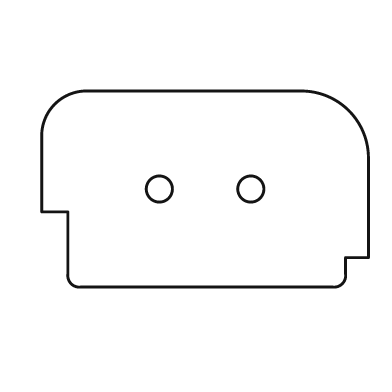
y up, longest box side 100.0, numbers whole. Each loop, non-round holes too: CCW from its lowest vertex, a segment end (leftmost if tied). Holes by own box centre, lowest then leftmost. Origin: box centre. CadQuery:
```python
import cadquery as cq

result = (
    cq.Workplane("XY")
    .moveTo(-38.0, -30.0)
    .lineTo(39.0, -30.0)
    .threePointArc((42.0, -29.0), (43.0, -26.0))
    .lineTo(43.0, -21.0)
    .lineTo(50.0, -21.0)
    .lineTo(50.0, 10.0)
    .threePointArc((44.0, 24.0), (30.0, 30.0))
    .lineTo(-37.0, 30.0)
    .threePointArc((-46.0, 26.0), (-50.0, 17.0))
    .lineTo(-50.0, -7.0)
    .lineTo(-42.0, -7.0)
    .lineTo(-42.0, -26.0)
    .threePointArc((-41.0, -29.0), (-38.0, -30.0))
    .close()
    .moveTo(-14.0, 0.0)
    .circle(4.0)
    .moveTo(14.0, 0.0)
    .circle(4.0)
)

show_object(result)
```